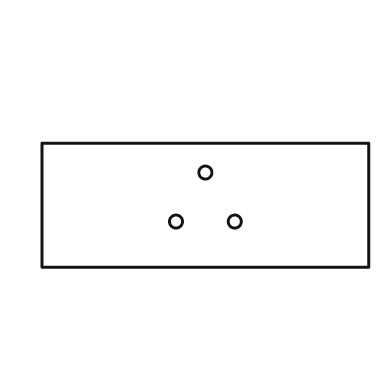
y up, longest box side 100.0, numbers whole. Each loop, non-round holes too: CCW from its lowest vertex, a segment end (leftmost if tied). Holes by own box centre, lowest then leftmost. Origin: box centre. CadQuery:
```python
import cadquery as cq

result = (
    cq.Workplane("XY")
    .moveTo(-50.0, -19.0)
    .lineTo(50.0, -19.0)
    .lineTo(50.0, 19.0)
    .lineTo(-50.0, 19.0)
    .close()
    .moveTo(-9.0, -5.0)
    .circle(2.0)
    .moveTo(9.0, -5.0)
    .circle(2.0)
    .moveTo(0.0, 10.0)
    .circle(2.0)
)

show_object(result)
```